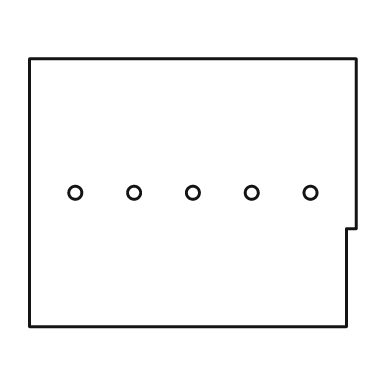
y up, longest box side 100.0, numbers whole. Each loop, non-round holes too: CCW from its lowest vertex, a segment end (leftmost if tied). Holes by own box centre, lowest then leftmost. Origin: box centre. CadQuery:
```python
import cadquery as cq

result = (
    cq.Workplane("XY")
    .moveTo(-50.0, -41.0)
    .lineTo(47.0, -41.0)
    .lineTo(47.0, -11.0)
    .lineTo(50.0, -11.0)
    .lineTo(50.0, 41.0)
    .lineTo(-50.0, 41.0)
    .close()
    .moveTo(-36.0, 0.0)
    .circle(2.0)
    .moveTo(-18.0, 0.0)
    .circle(2.0)
    .moveTo(0.0, 0.0)
    .circle(2.0)
    .moveTo(18.0, 0.0)
    .circle(2.0)
    .moveTo(36.0, 0.0)
    .circle(2.0)
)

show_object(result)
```